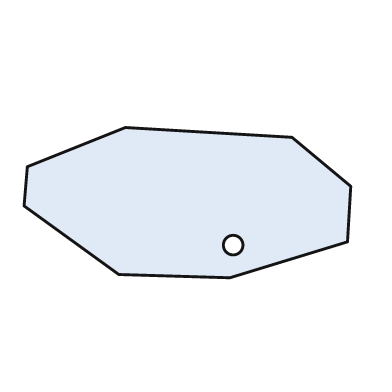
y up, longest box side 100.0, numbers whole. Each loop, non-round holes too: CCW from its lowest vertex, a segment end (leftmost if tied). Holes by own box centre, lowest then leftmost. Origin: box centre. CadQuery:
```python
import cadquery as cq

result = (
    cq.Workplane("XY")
    .moveTo(13.0, -23.0)
    .lineTo(49.0, -12.0)
    .lineTo(50.0, 5.0)
    .lineTo(32.0, 20.0)
    .lineTo(-19.0, 23.0)
    .lineTo(-49.0, 11.0)
    .lineTo(-50.0, -1.0)
    .lineTo(-21.0, -22.0)
    .close()
    .moveTo(14.0, -13.0)
    .circle(3.0)
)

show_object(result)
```